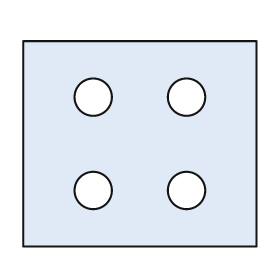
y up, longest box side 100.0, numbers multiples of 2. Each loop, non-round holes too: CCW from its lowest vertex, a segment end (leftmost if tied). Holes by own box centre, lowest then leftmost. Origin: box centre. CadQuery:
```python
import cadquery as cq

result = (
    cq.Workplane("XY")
    .moveTo(-50.0, -44.0)
    .lineTo(50.0, -44.0)
    .lineTo(50.0, 44.0)
    .lineTo(-50.0, 44.0)
    .close()
    .moveTo(-20.0, -20.0)
    .circle(8.0)
    .moveTo(20.0, -20.0)
    .circle(8.0)
    .moveTo(-20.0, 20.0)
    .circle(8.0)
    .moveTo(20.0, 20.0)
    .circle(8.0)
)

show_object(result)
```